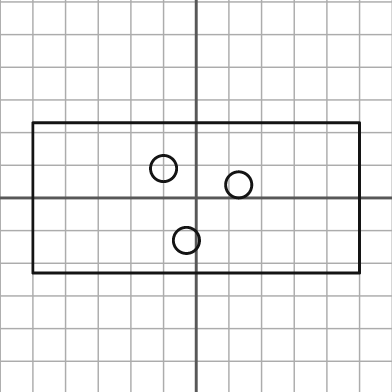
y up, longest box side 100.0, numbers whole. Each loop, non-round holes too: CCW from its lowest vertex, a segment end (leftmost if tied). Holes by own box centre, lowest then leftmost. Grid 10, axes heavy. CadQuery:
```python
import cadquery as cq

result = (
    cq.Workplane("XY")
    .moveTo(-50.0, -23.0)
    .lineTo(50.0, -23.0)
    .lineTo(50.0, 23.0)
    .lineTo(-50.0, 23.0)
    .close()
    .moveTo(-3.0, -13.0)
    .circle(4.0)
    .moveTo(13.0, 4.0)
    .circle(4.0)
    .moveTo(-10.0, 9.0)
    .circle(4.0)
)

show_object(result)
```